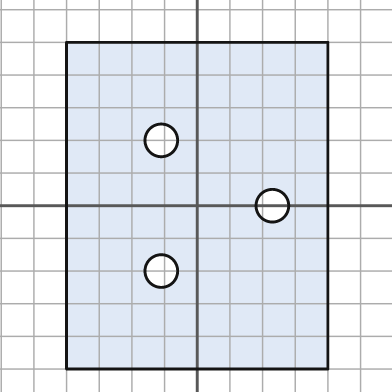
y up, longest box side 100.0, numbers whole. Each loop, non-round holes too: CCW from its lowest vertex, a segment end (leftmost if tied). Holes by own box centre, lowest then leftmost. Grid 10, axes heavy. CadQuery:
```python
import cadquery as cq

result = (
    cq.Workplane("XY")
    .moveTo(-40.0, -50.0)
    .lineTo(40.0, -50.0)
    .lineTo(40.0, 50.0)
    .lineTo(-40.0, 50.0)
    .close()
    .moveTo(-11.0, -20.0)
    .circle(5.0)
    .moveTo(23.0, 0.0)
    .circle(5.0)
    .moveTo(-11.0, 20.0)
    .circle(5.0)
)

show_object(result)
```